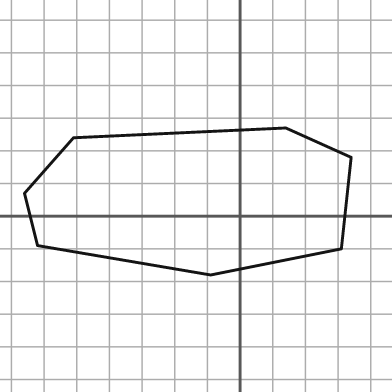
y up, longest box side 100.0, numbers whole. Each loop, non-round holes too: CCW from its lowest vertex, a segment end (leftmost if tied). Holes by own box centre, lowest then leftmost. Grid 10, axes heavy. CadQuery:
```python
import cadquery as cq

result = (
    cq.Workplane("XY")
    .moveTo(-9.0, -18.0)
    .lineTo(31.0, -10.0)
    .lineTo(34.0, 18.0)
    .lineTo(14.0, 27.0)
    .lineTo(-51.0, 24.0)
    .lineTo(-66.0, 7.0)
    .lineTo(-62.0, -9.0)
    .close()
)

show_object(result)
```